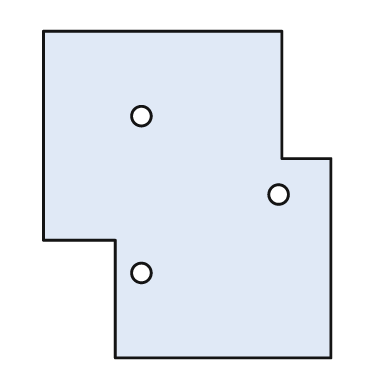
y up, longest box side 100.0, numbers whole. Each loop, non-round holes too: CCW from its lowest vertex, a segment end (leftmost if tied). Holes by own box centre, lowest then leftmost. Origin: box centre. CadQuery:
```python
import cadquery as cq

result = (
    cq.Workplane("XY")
    .moveTo(-22.0, -50.0)
    .lineTo(44.0, -50.0)
    .lineTo(44.0, 11.0)
    .lineTo(29.0, 11.0)
    .lineTo(29.0, 50.0)
    .lineTo(-44.0, 50.0)
    .lineTo(-44.0, -14.0)
    .lineTo(-22.0, -14.0)
    .close()
    .moveTo(-14.0, -24.0)
    .circle(3.0)
    .moveTo(28.0, 0.0)
    .circle(3.0)
    .moveTo(-14.0, 24.0)
    .circle(3.0)
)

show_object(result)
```